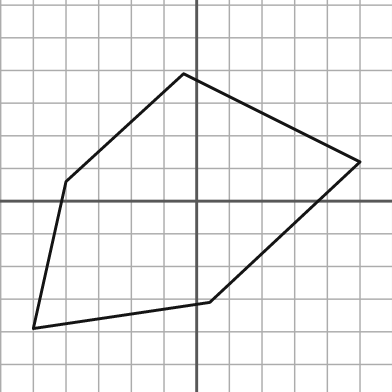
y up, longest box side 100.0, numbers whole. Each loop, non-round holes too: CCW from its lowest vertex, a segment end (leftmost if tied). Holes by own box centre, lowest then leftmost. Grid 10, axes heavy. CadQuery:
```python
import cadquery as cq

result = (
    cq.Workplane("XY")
    .moveTo(-50.0, -39.0)
    .lineTo(4.0, -31.0)
    .lineTo(50.0, 12.0)
    .lineTo(-4.0, 39.0)
    .lineTo(-40.0, 6.0)
    .close()
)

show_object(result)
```